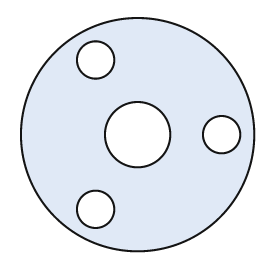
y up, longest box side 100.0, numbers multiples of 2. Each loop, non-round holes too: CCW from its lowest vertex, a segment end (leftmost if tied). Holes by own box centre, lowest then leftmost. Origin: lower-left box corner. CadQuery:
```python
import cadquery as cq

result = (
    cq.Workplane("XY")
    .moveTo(50.0, 50.0)
    .circle(50.0)
    .moveTo(32.0, 18.0)
    .circle(8.0)
    .moveTo(50.0, 50.0)
    .circle(14.0)
    .moveTo(86.0, 50.0)
    .circle(8.0)
    .moveTo(32.0, 82.0)
    .circle(8.0)
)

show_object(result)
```